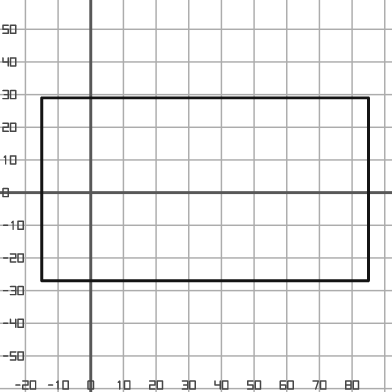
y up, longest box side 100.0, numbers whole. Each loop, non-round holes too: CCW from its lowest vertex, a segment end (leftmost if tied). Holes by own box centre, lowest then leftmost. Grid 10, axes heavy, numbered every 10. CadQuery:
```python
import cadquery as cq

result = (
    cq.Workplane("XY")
    .moveTo(-15.0, -27.0)
    .lineTo(85.0, -27.0)
    .lineTo(85.0, 29.0)
    .lineTo(-15.0, 29.0)
    .close()
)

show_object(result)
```